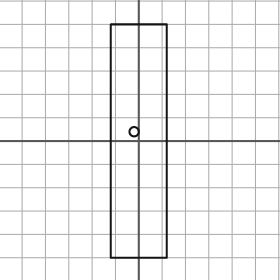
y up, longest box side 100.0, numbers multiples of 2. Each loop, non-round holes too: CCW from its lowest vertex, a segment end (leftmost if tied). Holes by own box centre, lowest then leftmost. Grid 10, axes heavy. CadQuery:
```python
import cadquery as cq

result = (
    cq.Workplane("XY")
    .moveTo(-12.0, -50.0)
    .lineTo(12.0, -50.0)
    .lineTo(12.0, 50.0)
    .lineTo(-12.0, 50.0)
    .close()
    .moveTo(-2.0, 4.0)
    .circle(2.0)
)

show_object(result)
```